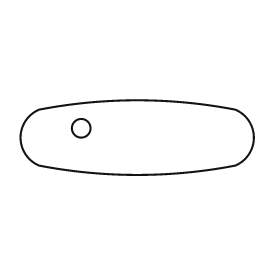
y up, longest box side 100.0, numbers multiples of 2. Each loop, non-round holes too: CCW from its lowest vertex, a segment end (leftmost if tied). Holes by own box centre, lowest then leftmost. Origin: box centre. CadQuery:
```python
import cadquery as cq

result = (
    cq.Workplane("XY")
    .moveTo(-42.0, -12.0)
    .threePointArc((0.0, -16.0), (42.0, -12.0))
    .threePointArc((50.0, 0.0), (42.0, 12.0))
    .threePointArc((0.0, 16.0), (-42.0, 12.0))
    .threePointArc((-50.0, 0.0), (-42.0, -12.0))
    .close()
    .moveTo(-24.0, 4.0)
    .circle(4.0)
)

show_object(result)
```